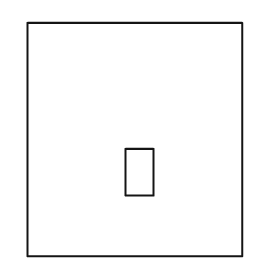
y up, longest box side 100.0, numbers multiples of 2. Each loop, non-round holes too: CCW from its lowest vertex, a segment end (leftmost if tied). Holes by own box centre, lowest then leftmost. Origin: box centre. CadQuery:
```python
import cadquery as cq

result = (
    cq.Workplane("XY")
    .moveTo(-46.0, -50.0)
    .lineTo(46.0, -50.0)
    .lineTo(46.0, 50.0)
    .lineTo(-46.0, 50.0)
    .close()
    .moveTo(-4.0, -24.0)
    .lineTo(8.0, -24.0)
    .lineTo(8.0, -4.0)
    .lineTo(-4.0, -4.0)
    .close()
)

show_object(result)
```